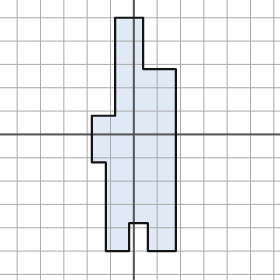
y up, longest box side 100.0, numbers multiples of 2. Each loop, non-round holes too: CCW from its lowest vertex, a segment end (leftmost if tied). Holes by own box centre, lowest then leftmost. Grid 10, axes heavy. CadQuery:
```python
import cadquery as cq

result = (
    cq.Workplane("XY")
    .moveTo(-12.0, -50.0)
    .lineTo(-2.0, -50.0)
    .lineTo(-2.0, -38.0)
    .lineTo(6.0, -38.0)
    .lineTo(6.0, -50.0)
    .lineTo(18.0, -50.0)
    .lineTo(18.0, 28.0)
    .lineTo(4.0, 28.0)
    .lineTo(4.0, 50.0)
    .lineTo(-8.0, 50.0)
    .lineTo(-8.0, 8.0)
    .lineTo(-18.0, 8.0)
    .lineTo(-18.0, -12.0)
    .lineTo(-12.0, -12.0)
    .close()
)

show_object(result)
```